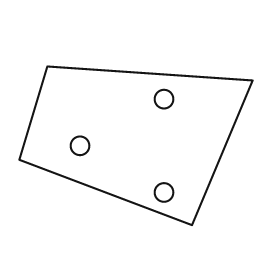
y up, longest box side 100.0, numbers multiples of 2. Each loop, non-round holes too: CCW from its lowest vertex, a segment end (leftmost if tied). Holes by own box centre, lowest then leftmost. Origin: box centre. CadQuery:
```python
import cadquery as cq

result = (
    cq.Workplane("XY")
    .moveTo(24.0, -34.0)
    .lineTo(50.0, 28.0)
    .lineTo(-38.0, 34.0)
    .lineTo(-50.0, -6.0)
    .close()
    .moveTo(12.0, -20.0)
    .circle(4.0)
    .moveTo(-24.0, 0.0)
    .circle(4.0)
    .moveTo(12.0, 20.0)
    .circle(4.0)
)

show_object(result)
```